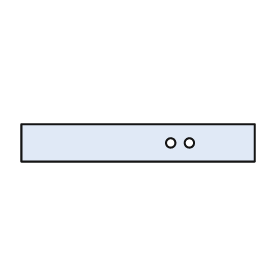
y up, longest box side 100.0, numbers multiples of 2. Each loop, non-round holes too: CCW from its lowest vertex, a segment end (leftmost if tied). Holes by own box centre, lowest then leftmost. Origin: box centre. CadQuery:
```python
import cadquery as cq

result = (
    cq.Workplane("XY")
    .moveTo(-50.0, -8.0)
    .lineTo(50.0, -8.0)
    .lineTo(50.0, 8.0)
    .lineTo(-50.0, 8.0)
    .close()
    .moveTo(14.0, 0.0)
    .circle(2.0)
    .moveTo(22.0, 0.0)
    .circle(2.0)
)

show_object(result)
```